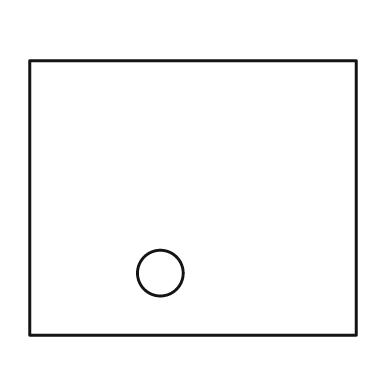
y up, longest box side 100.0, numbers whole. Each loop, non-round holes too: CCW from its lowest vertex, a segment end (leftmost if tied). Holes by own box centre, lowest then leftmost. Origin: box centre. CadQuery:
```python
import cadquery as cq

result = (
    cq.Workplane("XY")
    .moveTo(-50.0, -42.0)
    .lineTo(50.0, -42.0)
    .lineTo(50.0, 42.0)
    .lineTo(-50.0, 42.0)
    .close()
    .moveTo(-10.0, -23.0)
    .circle(7.0)
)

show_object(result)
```